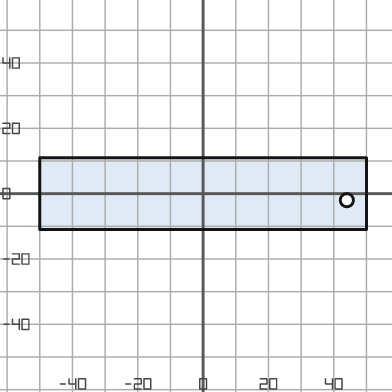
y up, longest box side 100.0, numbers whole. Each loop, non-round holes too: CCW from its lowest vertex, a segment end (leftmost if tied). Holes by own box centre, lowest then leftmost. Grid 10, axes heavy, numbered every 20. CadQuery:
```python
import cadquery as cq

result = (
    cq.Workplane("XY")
    .moveTo(-50.0, -11.0)
    .lineTo(50.0, -11.0)
    .lineTo(50.0, 11.0)
    .lineTo(-50.0, 11.0)
    .close()
    .moveTo(44.0, -2.0)
    .circle(2.0)
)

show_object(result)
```